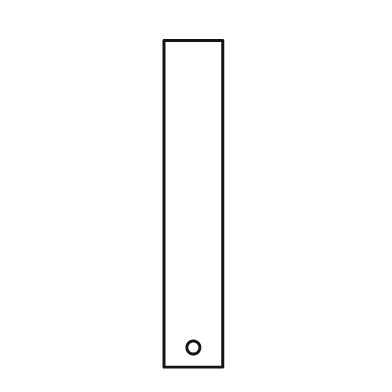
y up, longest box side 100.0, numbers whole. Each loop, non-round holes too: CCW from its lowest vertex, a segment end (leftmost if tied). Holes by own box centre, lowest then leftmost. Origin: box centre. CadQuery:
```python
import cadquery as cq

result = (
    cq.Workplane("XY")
    .moveTo(-9.0, -50.0)
    .lineTo(9.0, -50.0)
    .lineTo(9.0, 50.0)
    .lineTo(-9.0, 50.0)
    .close()
    .moveTo(0.0, -44.0)
    .circle(2.0)
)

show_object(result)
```